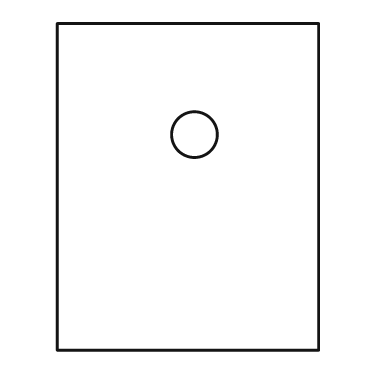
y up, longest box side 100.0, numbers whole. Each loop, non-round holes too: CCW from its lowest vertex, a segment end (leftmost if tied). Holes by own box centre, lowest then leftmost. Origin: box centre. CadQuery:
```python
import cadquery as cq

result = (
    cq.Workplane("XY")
    .moveTo(-40.0, -50.0)
    .lineTo(40.0, -50.0)
    .lineTo(40.0, 50.0)
    .lineTo(-40.0, 50.0)
    .close()
    .moveTo(2.0, 16.0)
    .circle(7.0)
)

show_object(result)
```